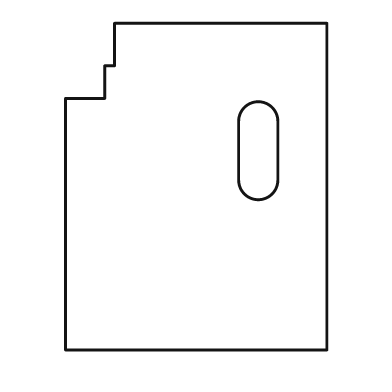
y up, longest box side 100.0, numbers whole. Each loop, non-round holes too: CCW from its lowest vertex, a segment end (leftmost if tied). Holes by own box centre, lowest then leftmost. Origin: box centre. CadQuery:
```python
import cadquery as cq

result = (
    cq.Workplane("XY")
    .moveTo(-40.0, -50.0)
    .lineTo(40.0, -50.0)
    .lineTo(40.0, 50.0)
    .lineTo(-25.0, 50.0)
    .lineTo(-25.0, 37.0)
    .lineTo(-28.0, 37.0)
    .lineTo(-28.0, 27.0)
    .lineTo(-40.0, 27.0)
    .close()
    .moveTo(13.0, 2.0)
    .threePointArc((19.0, -4.0), (25.0, 2.0))
    .lineTo(25.0, 20.0)
    .threePointArc((19.0, 26.0), (13.0, 20.0))
    .close()
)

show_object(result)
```